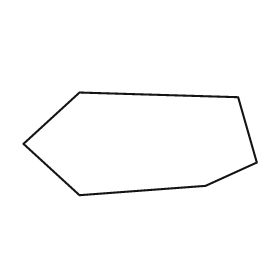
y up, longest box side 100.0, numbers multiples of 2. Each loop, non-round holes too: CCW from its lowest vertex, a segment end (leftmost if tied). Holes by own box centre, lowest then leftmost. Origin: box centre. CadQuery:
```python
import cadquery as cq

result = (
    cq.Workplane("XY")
    .moveTo(-26.0, -22.0)
    .lineTo(28.0, -18.0)
    .lineTo(50.0, -8.0)
    .lineTo(42.0, 20.0)
    .lineTo(-26.0, 22.0)
    .lineTo(-50.0, 0.0)
    .close()
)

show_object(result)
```